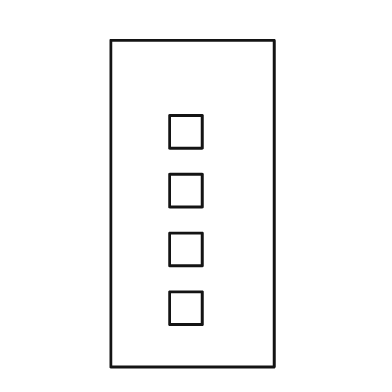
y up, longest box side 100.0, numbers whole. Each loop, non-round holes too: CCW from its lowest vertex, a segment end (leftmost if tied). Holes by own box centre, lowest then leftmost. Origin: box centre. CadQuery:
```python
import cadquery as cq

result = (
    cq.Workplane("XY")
    .moveTo(-25.0, -50.0)
    .lineTo(25.0, -50.0)
    .lineTo(25.0, 50.0)
    .lineTo(-25.0, 50.0)
    .close()
    .moveTo(-7.0, -37.0)
    .lineTo(3.0, -37.0)
    .lineTo(3.0, -27.0)
    .lineTo(-7.0, -27.0)
    .close()
    .moveTo(-7.0, -19.0)
    .lineTo(3.0, -19.0)
    .lineTo(3.0, -9.0)
    .lineTo(-7.0, -9.0)
    .close()
    .moveTo(-7.0, -1.0)
    .lineTo(3.0, -1.0)
    .lineTo(3.0, 9.0)
    .lineTo(-7.0, 9.0)
    .close()
    .moveTo(-7.0, 17.0)
    .lineTo(3.0, 17.0)
    .lineTo(3.0, 27.0)
    .lineTo(-7.0, 27.0)
    .close()
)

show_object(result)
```